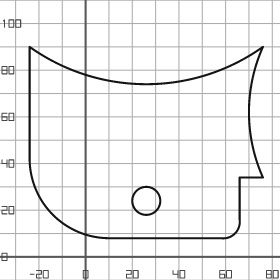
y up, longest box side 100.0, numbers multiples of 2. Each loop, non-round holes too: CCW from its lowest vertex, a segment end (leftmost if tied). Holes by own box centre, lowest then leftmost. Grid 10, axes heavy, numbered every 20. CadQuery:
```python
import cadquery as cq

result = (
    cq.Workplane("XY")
    .moveTo(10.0, 8.0)
    .lineTo(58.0, 8.0)
    .threePointArc((64.0, 10.0), (66.0, 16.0))
    .lineTo(66.0, 34.0)
    .lineTo(76.0, 34.0)
    .threePointArc((70.0, 62.0), (76.0, 90.0))
    .threePointArc((26.0, 74.0), (-24.0, 90.0))
    .lineTo(-24.0, 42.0)
    .threePointArc((-14.0, 18.0), (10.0, 8.0))
    .close()
    .moveTo(26.0, 24.0)
    .circle(6.0)
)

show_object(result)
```